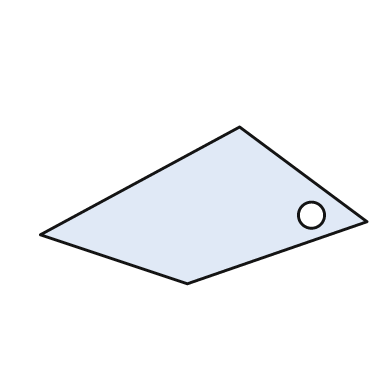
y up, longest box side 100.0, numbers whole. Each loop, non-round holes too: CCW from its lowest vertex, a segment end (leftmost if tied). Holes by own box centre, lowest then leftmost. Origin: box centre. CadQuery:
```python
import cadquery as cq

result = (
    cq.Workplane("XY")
    .moveTo(-5.0, -24.0)
    .lineTo(50.0, -5.0)
    .lineTo(11.0, 24.0)
    .lineTo(-50.0, -9.0)
    .close()
    .moveTo(33.0, -3.0)
    .circle(4.0)
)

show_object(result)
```